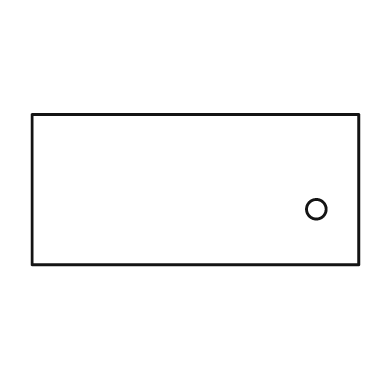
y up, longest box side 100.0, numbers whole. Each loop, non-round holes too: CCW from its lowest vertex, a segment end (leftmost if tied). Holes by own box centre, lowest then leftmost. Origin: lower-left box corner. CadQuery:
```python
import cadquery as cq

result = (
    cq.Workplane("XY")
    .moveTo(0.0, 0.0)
    .lineTo(100.0, 0.0)
    .lineTo(100.0, 46.0)
    .lineTo(0.0, 46.0)
    .close()
    .moveTo(87.0, 17.0)
    .circle(3.0)
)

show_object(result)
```